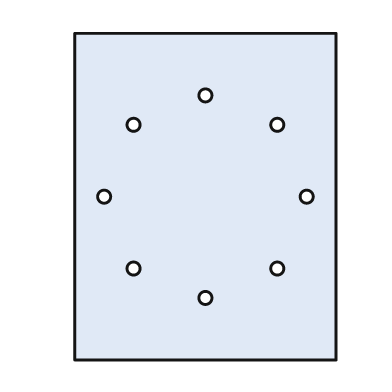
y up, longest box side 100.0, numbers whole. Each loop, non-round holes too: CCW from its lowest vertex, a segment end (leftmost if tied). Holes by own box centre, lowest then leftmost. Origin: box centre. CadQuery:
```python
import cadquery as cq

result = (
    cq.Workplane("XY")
    .moveTo(-40.0, -50.0)
    .lineTo(40.0, -50.0)
    .lineTo(40.0, 50.0)
    .lineTo(-40.0, 50.0)
    .close()
    .moveTo(0.0, -31.0)
    .circle(2.0)
    .moveTo(-22.0, -22.0)
    .circle(2.0)
    .moveTo(22.0, -22.0)
    .circle(2.0)
    .moveTo(-31.0, 0.0)
    .circle(2.0)
    .moveTo(31.0, 0.0)
    .circle(2.0)
    .moveTo(-22.0, 22.0)
    .circle(2.0)
    .moveTo(22.0, 22.0)
    .circle(2.0)
    .moveTo(0.0, 31.0)
    .circle(2.0)
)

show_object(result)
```